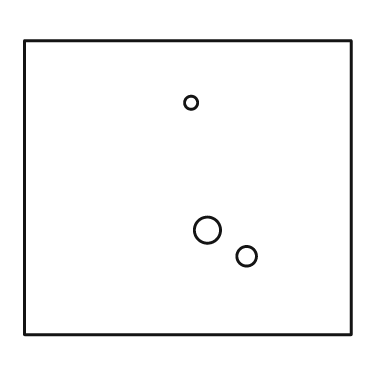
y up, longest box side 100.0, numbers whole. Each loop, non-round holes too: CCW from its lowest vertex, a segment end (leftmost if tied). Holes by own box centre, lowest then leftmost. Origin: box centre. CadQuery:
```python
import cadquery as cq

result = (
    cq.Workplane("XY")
    .moveTo(-50.0, -45.0)
    .lineTo(50.0, -45.0)
    .lineTo(50.0, 45.0)
    .lineTo(-50.0, 45.0)
    .close()
    .moveTo(18.0, -21.0)
    .circle(3.0)
    .moveTo(6.0, -13.0)
    .circle(4.0)
    .moveTo(1.0, 26.0)
    .circle(2.0)
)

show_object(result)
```